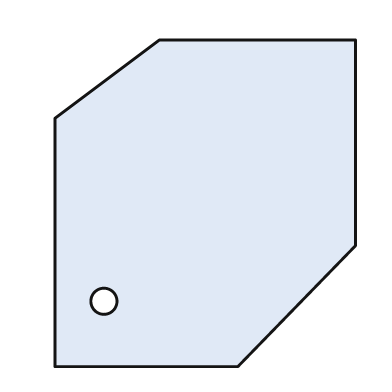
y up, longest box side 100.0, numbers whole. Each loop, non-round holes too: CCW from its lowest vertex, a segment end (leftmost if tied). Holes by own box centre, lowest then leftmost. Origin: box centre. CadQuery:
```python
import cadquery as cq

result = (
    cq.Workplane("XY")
    .moveTo(-46.0, -50.0)
    .lineTo(10.0, -50.0)
    .lineTo(46.0, -13.0)
    .lineTo(46.0, 50.0)
    .lineTo(-14.0, 50.0)
    .lineTo(-46.0, 26.0)
    .close()
    .moveTo(-31.0, -30.0)
    .circle(4.0)
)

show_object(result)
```